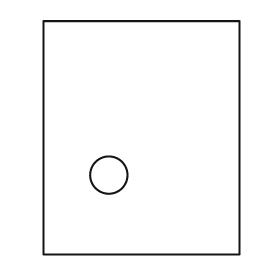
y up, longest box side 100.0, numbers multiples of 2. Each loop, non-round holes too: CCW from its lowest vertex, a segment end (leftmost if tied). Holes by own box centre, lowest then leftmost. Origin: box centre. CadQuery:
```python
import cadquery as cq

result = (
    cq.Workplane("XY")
    .moveTo(-42.0, -50.0)
    .lineTo(42.0, -50.0)
    .lineTo(42.0, 50.0)
    .lineTo(-42.0, 50.0)
    .close()
    .moveTo(-14.0, -16.0)
    .circle(8.0)
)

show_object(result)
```